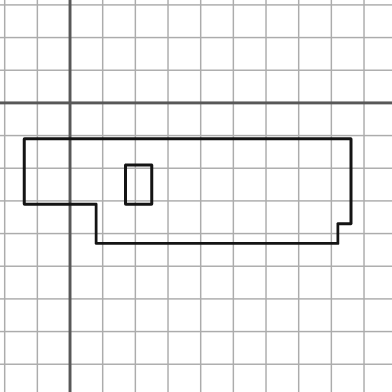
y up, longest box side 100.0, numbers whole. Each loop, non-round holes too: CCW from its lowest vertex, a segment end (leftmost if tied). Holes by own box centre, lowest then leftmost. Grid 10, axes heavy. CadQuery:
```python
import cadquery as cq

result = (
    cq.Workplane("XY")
    .moveTo(8.0, -43.0)
    .lineTo(82.0, -43.0)
    .lineTo(82.0, -37.0)
    .lineTo(86.0, -37.0)
    .lineTo(86.0, -11.0)
    .lineTo(-14.0, -11.0)
    .lineTo(-14.0, -31.0)
    .lineTo(8.0, -31.0)
    .close()
    .moveTo(17.0, -31.0)
    .lineTo(25.0, -31.0)
    .lineTo(25.0, -19.0)
    .lineTo(17.0, -19.0)
    .close()
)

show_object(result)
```